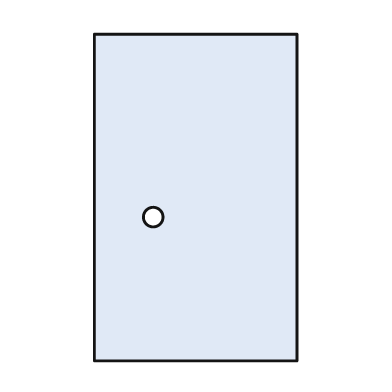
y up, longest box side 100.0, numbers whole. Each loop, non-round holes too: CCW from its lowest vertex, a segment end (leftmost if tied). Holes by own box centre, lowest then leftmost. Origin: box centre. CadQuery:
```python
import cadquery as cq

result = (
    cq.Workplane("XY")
    .moveTo(-31.0, -50.0)
    .lineTo(31.0, -50.0)
    .lineTo(31.0, 50.0)
    .lineTo(-31.0, 50.0)
    .close()
    .moveTo(-13.0, -6.0)
    .circle(3.0)
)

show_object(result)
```